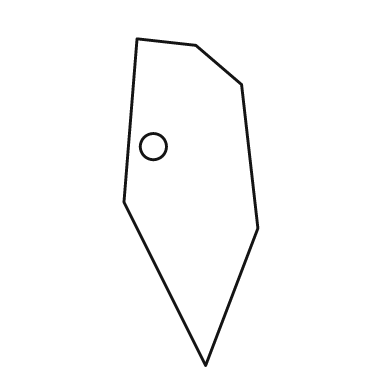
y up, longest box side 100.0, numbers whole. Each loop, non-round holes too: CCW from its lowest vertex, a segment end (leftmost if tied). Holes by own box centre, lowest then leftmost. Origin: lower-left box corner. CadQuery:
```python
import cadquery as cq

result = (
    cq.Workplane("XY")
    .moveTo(25.0, 0.0)
    .lineTo(41.0, 42.0)
    .lineTo(36.0, 86.0)
    .lineTo(22.0, 98.0)
    .lineTo(4.0, 100.0)
    .lineTo(0.0, 50.0)
    .close()
    .moveTo(9.0, 67.0)
    .circle(4.0)
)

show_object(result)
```